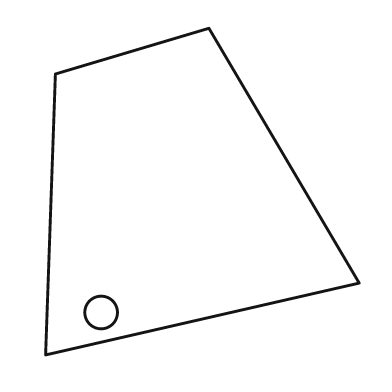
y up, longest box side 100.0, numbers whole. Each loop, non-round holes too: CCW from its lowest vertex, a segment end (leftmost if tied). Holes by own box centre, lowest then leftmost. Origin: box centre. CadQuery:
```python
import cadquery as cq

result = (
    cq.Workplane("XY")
    .moveTo(-48.0, -50.0)
    .lineTo(48.0, -28.0)
    .lineTo(2.0, 50.0)
    .lineTo(-45.0, 36.0)
    .close()
    .moveTo(-31.0, -37.0)
    .circle(5.0)
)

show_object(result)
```